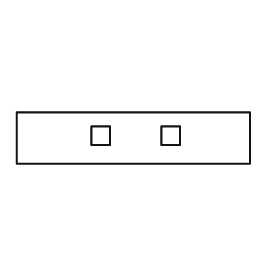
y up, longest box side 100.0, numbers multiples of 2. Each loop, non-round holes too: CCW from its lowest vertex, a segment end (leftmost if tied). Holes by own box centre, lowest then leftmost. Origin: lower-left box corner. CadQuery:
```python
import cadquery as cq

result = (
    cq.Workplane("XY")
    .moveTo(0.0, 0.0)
    .lineTo(100.0, 0.0)
    .lineTo(100.0, 22.0)
    .lineTo(0.0, 22.0)
    .close()
    .moveTo(32.0, 8.0)
    .lineTo(40.0, 8.0)
    .lineTo(40.0, 16.0)
    .lineTo(32.0, 16.0)
    .close()
    .moveTo(62.0, 8.0)
    .lineTo(70.0, 8.0)
    .lineTo(70.0, 16.0)
    .lineTo(62.0, 16.0)
    .close()
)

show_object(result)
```